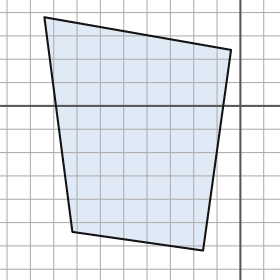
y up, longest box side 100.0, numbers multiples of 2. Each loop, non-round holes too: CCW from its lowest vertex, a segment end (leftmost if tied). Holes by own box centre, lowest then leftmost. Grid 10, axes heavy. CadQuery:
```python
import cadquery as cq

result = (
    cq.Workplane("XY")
    .moveTo(-16.0, -62.0)
    .lineTo(-4.0, 24.0)
    .lineTo(-84.0, 38.0)
    .lineTo(-72.0, -54.0)
    .close()
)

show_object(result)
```